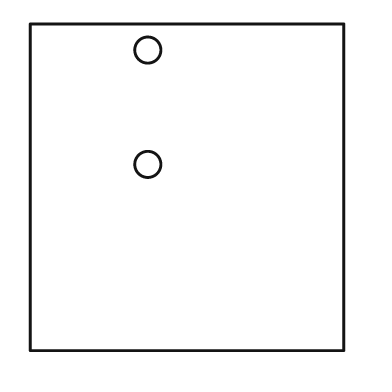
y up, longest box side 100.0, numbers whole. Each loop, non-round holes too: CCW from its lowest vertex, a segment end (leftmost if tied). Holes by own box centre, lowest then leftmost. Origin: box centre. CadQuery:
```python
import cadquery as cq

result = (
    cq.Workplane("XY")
    .moveTo(-48.0, -50.0)
    .lineTo(48.0, -50.0)
    .lineTo(48.0, 50.0)
    .lineTo(-48.0, 50.0)
    .close()
    .moveTo(-12.0, 7.0)
    .circle(4.0)
    .moveTo(-12.0, 42.0)
    .circle(4.0)
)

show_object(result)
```